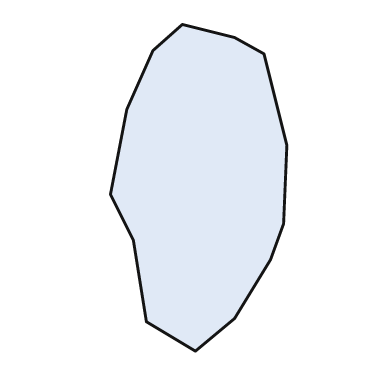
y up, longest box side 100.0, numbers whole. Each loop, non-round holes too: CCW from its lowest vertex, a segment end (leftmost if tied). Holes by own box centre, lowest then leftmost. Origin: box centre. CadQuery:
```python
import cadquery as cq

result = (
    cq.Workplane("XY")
    .moveTo(-1.0, -50.0)
    .lineTo(11.0, -40.0)
    .lineTo(22.0, -22.0)
    .lineTo(26.0, -11.0)
    .lineTo(27.0, 13.0)
    .lineTo(20.0, 41.0)
    .lineTo(11.0, 46.0)
    .lineTo(-5.0, 50.0)
    .lineTo(-14.0, 42.0)
    .lineTo(-22.0, 24.0)
    .lineTo(-27.0, -2.0)
    .lineTo(-20.0, -16.0)
    .lineTo(-16.0, -41.0)
    .close()
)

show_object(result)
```